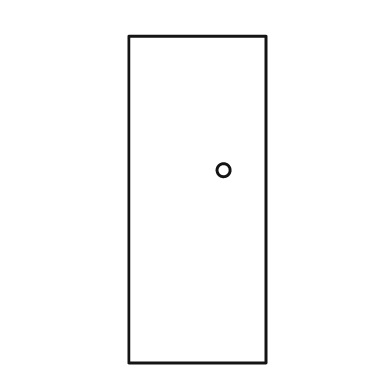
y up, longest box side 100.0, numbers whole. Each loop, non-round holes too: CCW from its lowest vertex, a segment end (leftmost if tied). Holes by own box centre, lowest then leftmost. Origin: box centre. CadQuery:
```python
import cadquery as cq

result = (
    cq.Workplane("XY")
    .moveTo(-21.0, -50.0)
    .lineTo(21.0, -50.0)
    .lineTo(21.0, 50.0)
    .lineTo(-21.0, 50.0)
    .close()
    .moveTo(8.0, 9.0)
    .circle(2.0)
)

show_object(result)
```